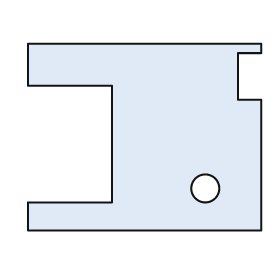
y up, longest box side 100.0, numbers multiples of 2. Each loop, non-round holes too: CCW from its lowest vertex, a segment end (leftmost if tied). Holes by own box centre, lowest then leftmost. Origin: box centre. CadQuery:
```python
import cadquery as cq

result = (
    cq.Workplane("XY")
    .moveTo(-50.0, -40.0)
    .lineTo(50.0, -40.0)
    .lineTo(50.0, 16.0)
    .lineTo(40.0, 16.0)
    .lineTo(40.0, 36.0)
    .lineTo(50.0, 36.0)
    .lineTo(50.0, 40.0)
    .lineTo(-50.0, 40.0)
    .lineTo(-50.0, 22.0)
    .lineTo(-14.0, 22.0)
    .lineTo(-14.0, -28.0)
    .lineTo(-50.0, -28.0)
    .close()
    .moveTo(26.0, -22.0)
    .circle(6.0)
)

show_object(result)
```